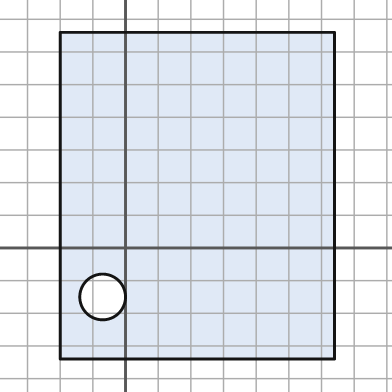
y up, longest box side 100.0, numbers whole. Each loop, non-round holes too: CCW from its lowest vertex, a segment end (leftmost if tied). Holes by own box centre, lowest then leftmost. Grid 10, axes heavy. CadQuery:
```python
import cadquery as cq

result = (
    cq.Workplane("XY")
    .moveTo(-20.0, -34.0)
    .lineTo(64.0, -34.0)
    .lineTo(64.0, 66.0)
    .lineTo(-20.0, 66.0)
    .close()
    .moveTo(-7.0, -15.0)
    .circle(7.0)
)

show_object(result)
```